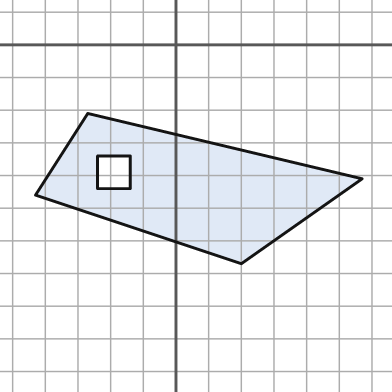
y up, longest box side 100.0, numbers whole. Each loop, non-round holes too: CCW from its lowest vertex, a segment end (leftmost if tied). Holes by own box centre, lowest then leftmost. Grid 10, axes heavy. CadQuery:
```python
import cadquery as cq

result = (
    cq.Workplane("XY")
    .moveTo(20.0, -67.0)
    .lineTo(57.0, -41.0)
    .lineTo(-27.0, -21.0)
    .lineTo(-43.0, -46.0)
    .close()
    .moveTo(-24.0, -44.0)
    .lineTo(-14.0, -44.0)
    .lineTo(-14.0, -34.0)
    .lineTo(-24.0, -34.0)
    .close()
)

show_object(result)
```